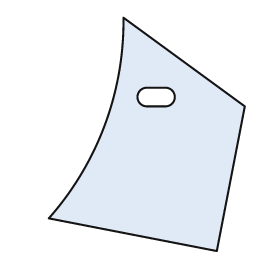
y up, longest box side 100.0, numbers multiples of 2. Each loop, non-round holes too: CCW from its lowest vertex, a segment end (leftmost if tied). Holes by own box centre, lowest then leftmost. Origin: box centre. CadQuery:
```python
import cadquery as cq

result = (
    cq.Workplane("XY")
    .moveTo(30.0, -50.0)
    .lineTo(42.0, 12.0)
    .lineTo(-10.0, 50.0)
    .threePointArc((-18.0, 4.0), (-42.0, -36.0))
    .close()
    .moveTo(0.0, 12.0)
    .lineTo(8.0, 12.0)
    .threePointArc((12.0, 16.0), (8.0, 20.0))
    .lineTo(0.0, 20.0)
    .threePointArc((-4.0, 16.0), (0.0, 12.0))
    .close()
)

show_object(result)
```